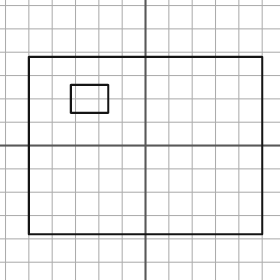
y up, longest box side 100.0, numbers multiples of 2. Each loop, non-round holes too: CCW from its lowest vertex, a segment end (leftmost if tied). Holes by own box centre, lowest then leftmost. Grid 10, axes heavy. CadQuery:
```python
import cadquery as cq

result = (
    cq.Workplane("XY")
    .moveTo(-50.0, -38.0)
    .lineTo(50.0, -38.0)
    .lineTo(50.0, 38.0)
    .lineTo(-50.0, 38.0)
    .close()
    .moveTo(-32.0, 14.0)
    .lineTo(-16.0, 14.0)
    .lineTo(-16.0, 26.0)
    .lineTo(-32.0, 26.0)
    .close()
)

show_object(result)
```